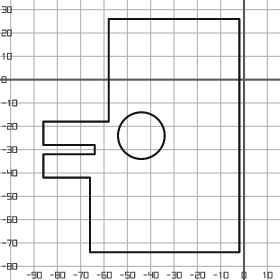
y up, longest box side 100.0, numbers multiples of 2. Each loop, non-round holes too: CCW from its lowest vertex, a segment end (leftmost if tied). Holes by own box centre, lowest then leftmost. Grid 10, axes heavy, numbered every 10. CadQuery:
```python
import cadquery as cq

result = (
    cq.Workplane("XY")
    .moveTo(-66.0, -74.0)
    .lineTo(-2.0, -74.0)
    .lineTo(-2.0, 26.0)
    .lineTo(-58.0, 26.0)
    .lineTo(-58.0, -18.0)
    .lineTo(-86.0, -18.0)
    .lineTo(-86.0, -28.0)
    .lineTo(-64.0, -28.0)
    .lineTo(-64.0, -32.0)
    .lineTo(-86.0, -32.0)
    .lineTo(-86.0, -42.0)
    .lineTo(-66.0, -42.0)
    .close()
    .moveTo(-44.0, -24.0)
    .circle(10.0)
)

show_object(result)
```